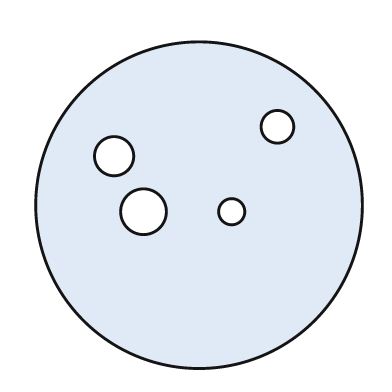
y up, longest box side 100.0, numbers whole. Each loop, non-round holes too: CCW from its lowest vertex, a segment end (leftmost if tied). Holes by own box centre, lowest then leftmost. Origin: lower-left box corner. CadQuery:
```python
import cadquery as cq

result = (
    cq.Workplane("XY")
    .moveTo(50.0, 50.0)
    .circle(50.0)
    .moveTo(33.0, 48.0)
    .circle(7.0)
    .moveTo(60.0, 48.0)
    .circle(4.0)
    .moveTo(24.0, 65.0)
    .circle(6.0)
    .moveTo(74.0, 74.0)
    .circle(5.0)
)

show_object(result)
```